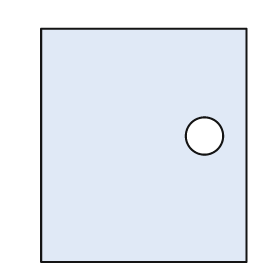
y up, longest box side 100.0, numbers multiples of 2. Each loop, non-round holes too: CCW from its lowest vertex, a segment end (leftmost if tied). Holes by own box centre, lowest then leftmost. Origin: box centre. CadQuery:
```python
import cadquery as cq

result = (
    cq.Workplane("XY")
    .moveTo(-44.0, -50.0)
    .lineTo(44.0, -50.0)
    .lineTo(44.0, 50.0)
    .lineTo(-44.0, 50.0)
    .close()
    .moveTo(26.0, 4.0)
    .circle(8.0)
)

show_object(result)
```